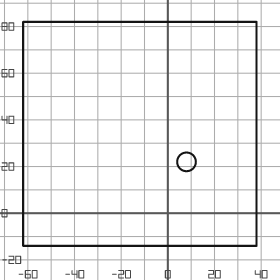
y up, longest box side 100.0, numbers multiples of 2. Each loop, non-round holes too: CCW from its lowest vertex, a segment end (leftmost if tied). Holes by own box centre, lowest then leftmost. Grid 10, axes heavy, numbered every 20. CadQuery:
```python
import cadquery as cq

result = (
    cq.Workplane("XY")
    .moveTo(-62.0, -14.0)
    .lineTo(38.0, -14.0)
    .lineTo(38.0, 82.0)
    .lineTo(-62.0, 82.0)
    .close()
    .moveTo(8.0, 22.0)
    .circle(4.0)
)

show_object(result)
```